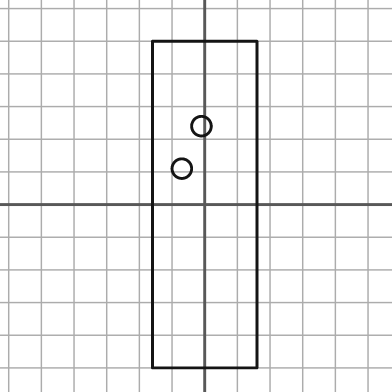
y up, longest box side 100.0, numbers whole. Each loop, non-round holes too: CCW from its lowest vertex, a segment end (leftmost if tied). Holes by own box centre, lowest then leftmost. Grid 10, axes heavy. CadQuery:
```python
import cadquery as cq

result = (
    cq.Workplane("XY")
    .moveTo(-16.0, -50.0)
    .lineTo(16.0, -50.0)
    .lineTo(16.0, 50.0)
    .lineTo(-16.0, 50.0)
    .close()
    .moveTo(-7.0, 11.0)
    .circle(3.0)
    .moveTo(-1.0, 24.0)
    .circle(3.0)
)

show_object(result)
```